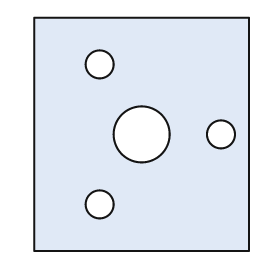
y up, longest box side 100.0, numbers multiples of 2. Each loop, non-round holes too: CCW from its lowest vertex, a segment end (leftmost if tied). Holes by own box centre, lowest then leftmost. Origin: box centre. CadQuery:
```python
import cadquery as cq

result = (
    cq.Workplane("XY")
    .moveTo(-46.0, -50.0)
    .lineTo(46.0, -50.0)
    .lineTo(46.0, 50.0)
    .lineTo(-46.0, 50.0)
    .close()
    .moveTo(-18.0, -30.0)
    .circle(6.0)
    .moveTo(0.0, 0.0)
    .circle(12.0)
    .moveTo(34.0, 0.0)
    .circle(6.0)
    .moveTo(-18.0, 30.0)
    .circle(6.0)
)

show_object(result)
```